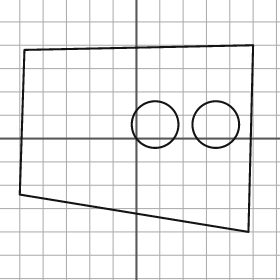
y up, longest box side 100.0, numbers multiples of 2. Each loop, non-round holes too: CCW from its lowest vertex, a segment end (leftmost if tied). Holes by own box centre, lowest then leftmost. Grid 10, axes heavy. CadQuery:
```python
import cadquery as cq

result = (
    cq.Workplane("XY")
    .moveTo(48.0, -40.0)
    .lineTo(50.0, 40.0)
    .lineTo(-48.0, 38.0)
    .lineTo(-50.0, -24.0)
    .close()
    .moveTo(8.0, 6.0)
    .circle(10.0)
    .moveTo(34.0, 6.0)
    .circle(10.0)
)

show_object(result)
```